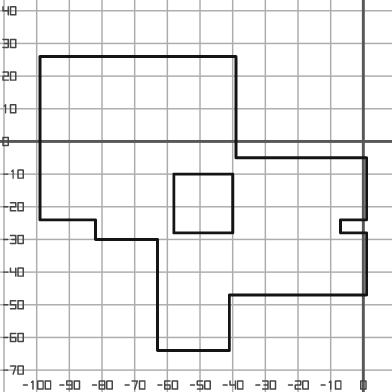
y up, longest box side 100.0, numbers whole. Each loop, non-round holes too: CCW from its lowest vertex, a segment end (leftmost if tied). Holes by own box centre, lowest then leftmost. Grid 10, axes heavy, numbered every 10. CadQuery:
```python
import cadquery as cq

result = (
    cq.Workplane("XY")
    .moveTo(-63.0, -64.0)
    .lineTo(-41.0, -64.0)
    .lineTo(-41.0, -47.0)
    .lineTo(1.0, -47.0)
    .lineTo(1.0, -28.0)
    .lineTo(-7.0, -28.0)
    .lineTo(-7.0, -24.0)
    .lineTo(1.0, -24.0)
    .lineTo(1.0, -5.0)
    .lineTo(-39.0, -5.0)
    .lineTo(-39.0, 26.0)
    .lineTo(-99.0, 26.0)
    .lineTo(-99.0, -24.0)
    .lineTo(-82.0, -24.0)
    .lineTo(-82.0, -30.0)
    .lineTo(-63.0, -30.0)
    .close()
    .moveTo(-58.0, -28.0)
    .lineTo(-40.0, -28.0)
    .lineTo(-40.0, -10.0)
    .lineTo(-58.0, -10.0)
    .close()
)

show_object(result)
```